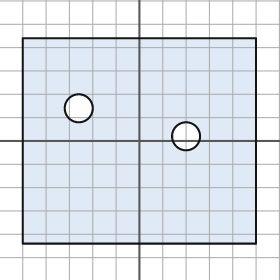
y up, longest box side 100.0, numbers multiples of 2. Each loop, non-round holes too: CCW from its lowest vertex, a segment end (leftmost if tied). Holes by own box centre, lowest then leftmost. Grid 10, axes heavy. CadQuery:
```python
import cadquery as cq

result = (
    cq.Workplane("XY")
    .moveTo(-50.0, -44.0)
    .lineTo(50.0, -44.0)
    .lineTo(50.0, 44.0)
    .lineTo(-50.0, 44.0)
    .close()
    .moveTo(20.0, 2.0)
    .circle(6.0)
    .moveTo(-26.0, 14.0)
    .circle(6.0)
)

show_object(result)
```